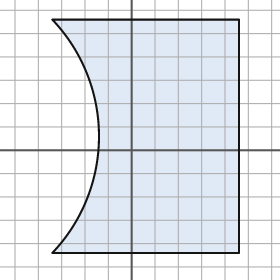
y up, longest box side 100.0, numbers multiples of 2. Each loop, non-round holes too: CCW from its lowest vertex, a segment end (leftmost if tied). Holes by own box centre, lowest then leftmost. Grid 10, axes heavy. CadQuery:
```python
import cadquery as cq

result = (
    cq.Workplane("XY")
    .moveTo(-34.0, -44.0)
    .lineTo(46.0, -44.0)
    .lineTo(46.0, 56.0)
    .lineTo(-34.0, 56.0)
    .threePointArc((-14.0, 6.0), (-34.0, -44.0))
    .close()
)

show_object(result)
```